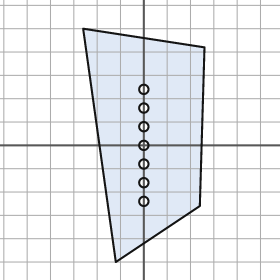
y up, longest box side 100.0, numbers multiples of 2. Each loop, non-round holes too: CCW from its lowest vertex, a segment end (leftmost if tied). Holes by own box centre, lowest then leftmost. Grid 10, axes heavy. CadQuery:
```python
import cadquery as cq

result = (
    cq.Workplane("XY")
    .moveTo(-12.0, -50.0)
    .lineTo(24.0, -26.0)
    .lineTo(26.0, 42.0)
    .lineTo(-26.0, 50.0)
    .close()
    .moveTo(0.0, -24.0)
    .circle(2.0)
    .moveTo(0.0, -16.0)
    .circle(2.0)
    .moveTo(0.0, -8.0)
    .circle(2.0)
    .moveTo(0.0, 0.0)
    .circle(2.0)
    .moveTo(0.0, 8.0)
    .circle(2.0)
    .moveTo(0.0, 16.0)
    .circle(2.0)
    .moveTo(0.0, 24.0)
    .circle(2.0)
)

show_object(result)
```